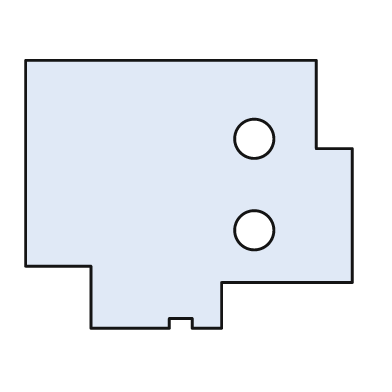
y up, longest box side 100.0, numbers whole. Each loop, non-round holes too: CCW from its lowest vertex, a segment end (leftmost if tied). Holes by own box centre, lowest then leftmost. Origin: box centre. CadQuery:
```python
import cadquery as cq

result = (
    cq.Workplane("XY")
    .moveTo(-30.0, -41.0)
    .lineTo(-6.0, -41.0)
    .lineTo(-6.0, -38.0)
    .lineTo(1.0, -38.0)
    .lineTo(1.0, -41.0)
    .lineTo(10.0, -41.0)
    .lineTo(10.0, -27.0)
    .lineTo(50.0, -27.0)
    .lineTo(50.0, 14.0)
    .lineTo(39.0, 14.0)
    .lineTo(39.0, 41.0)
    .lineTo(-50.0, 41.0)
    .lineTo(-50.0, -22.0)
    .lineTo(-30.0, -22.0)
    .close()
    .moveTo(20.0, -11.0)
    .circle(6.0)
    .moveTo(20.0, 17.0)
    .circle(6.0)
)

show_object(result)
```